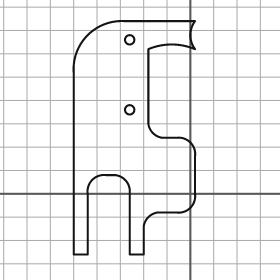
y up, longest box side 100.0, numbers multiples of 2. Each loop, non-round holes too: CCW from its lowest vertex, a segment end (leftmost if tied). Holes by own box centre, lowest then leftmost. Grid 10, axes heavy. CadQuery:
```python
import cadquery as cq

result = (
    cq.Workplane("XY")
    .moveTo(-50.0, -26.0)
    .lineTo(-44.0, -26.0)
    .lineTo(-44.0, 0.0)
    .threePointArc((-42.0, 6.0), (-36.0, 8.0))
    .lineTo(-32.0, 8.0)
    .threePointArc((-28.0, 6.0), (-26.0, 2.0))
    .lineTo(-26.0, -26.0)
    .lineTo(-20.0, -26.0)
    .lineTo(-20.0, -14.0)
    .threePointArc((-18.0, -10.0), (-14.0, -8.0))
    .lineTo(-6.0, -8.0)
    .threePointArc((0.0, -6.0), (2.0, 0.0))
    .lineTo(2.0, 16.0)
    .threePointArc((0.0, 22.0), (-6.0, 24.0))
    .lineTo(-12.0, 24.0)
    .threePointArc((-16.0, 26.0), (-18.0, 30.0))
    .lineTo(-18.0, 62.0)
    .threePointArc((-8.0, 64.0), (2.0, 62.0))
    .threePointArc((0.0, 68.0), (2.0, 74.0))
    .lineTo(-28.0, 74.0)
    .threePointArc((-44.0, 68.0), (-50.0, 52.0))
    .close()
    .moveTo(-26.0, 36.0)
    .circle(2.0)
    .moveTo(-26.0, 66.0)
    .circle(2.0)
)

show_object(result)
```